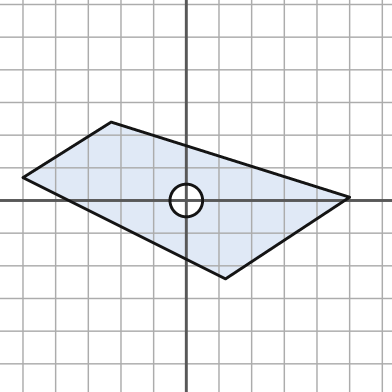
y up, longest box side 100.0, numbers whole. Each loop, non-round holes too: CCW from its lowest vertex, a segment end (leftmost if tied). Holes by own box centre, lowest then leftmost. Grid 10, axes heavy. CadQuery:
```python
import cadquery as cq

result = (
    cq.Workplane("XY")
    .moveTo(12.0, -24.0)
    .lineTo(50.0, 1.0)
    .lineTo(-23.0, 24.0)
    .lineTo(-50.0, 7.0)
    .close()
    .moveTo(0.0, 0.0)
    .circle(5.0)
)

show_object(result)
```